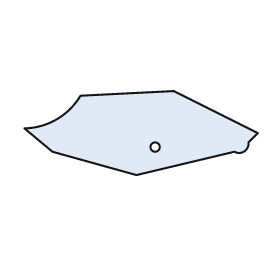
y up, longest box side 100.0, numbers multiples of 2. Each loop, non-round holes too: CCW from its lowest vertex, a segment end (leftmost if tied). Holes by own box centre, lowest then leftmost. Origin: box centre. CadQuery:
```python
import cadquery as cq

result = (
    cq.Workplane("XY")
    .moveTo(-2.0, -18.0)
    .lineTo(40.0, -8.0)
    .threePointArc((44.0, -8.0), (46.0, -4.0))
    .lineTo(50.0, 0.0)
    .lineTo(14.0, 18.0)
    .lineTo(-26.0, 16.0)
    .threePointArc((-36.0, 6.0), (-50.0, 2.0))
    .lineTo(-38.0, -8.0)
    .close()
    .moveTo(6.0, -6.0)
    .circle(2.0)
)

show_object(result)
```